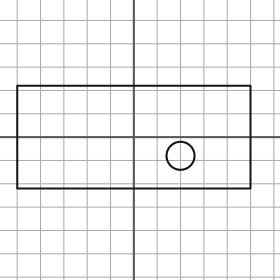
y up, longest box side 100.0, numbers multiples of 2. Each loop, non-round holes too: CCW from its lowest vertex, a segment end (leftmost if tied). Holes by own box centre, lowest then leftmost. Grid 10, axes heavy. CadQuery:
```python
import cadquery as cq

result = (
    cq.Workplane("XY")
    .moveTo(-50.0, -22.0)
    .lineTo(50.0, -22.0)
    .lineTo(50.0, 22.0)
    .lineTo(-50.0, 22.0)
    .close()
    .moveTo(20.0, -8.0)
    .circle(6.0)
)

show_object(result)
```